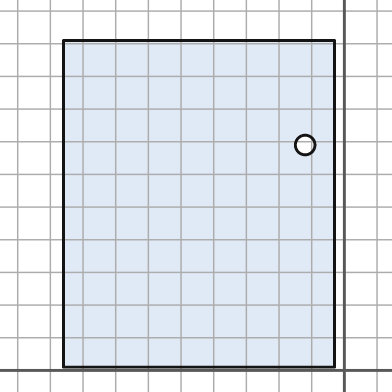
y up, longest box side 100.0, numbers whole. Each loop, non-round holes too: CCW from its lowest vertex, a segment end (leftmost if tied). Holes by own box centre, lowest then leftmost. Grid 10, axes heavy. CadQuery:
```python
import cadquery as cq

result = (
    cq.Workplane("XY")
    .moveTo(-86.0, 1.0)
    .lineTo(-3.0, 1.0)
    .lineTo(-3.0, 101.0)
    .lineTo(-86.0, 101.0)
    .close()
    .moveTo(-12.0, 69.0)
    .circle(3.0)
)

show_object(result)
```